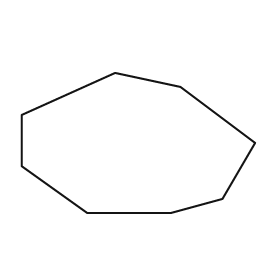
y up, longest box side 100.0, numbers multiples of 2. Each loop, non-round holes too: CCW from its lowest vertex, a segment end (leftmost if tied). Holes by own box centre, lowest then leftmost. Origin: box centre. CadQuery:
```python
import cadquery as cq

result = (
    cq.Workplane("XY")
    .moveTo(-22.0, -30.0)
    .lineTo(14.0, -30.0)
    .lineTo(36.0, -24.0)
    .lineTo(50.0, 0.0)
    .lineTo(18.0, 24.0)
    .lineTo(-10.0, 30.0)
    .lineTo(-50.0, 12.0)
    .lineTo(-50.0, -10.0)
    .close()
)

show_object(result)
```